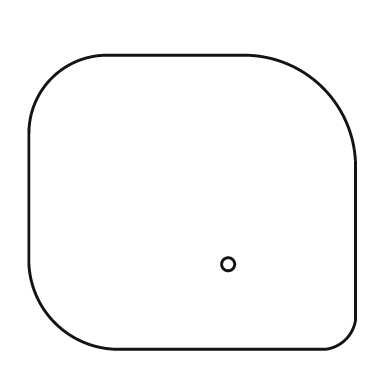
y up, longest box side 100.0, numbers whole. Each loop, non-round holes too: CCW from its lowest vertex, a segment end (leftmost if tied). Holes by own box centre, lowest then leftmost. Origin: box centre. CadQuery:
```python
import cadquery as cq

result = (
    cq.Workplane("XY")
    .moveTo(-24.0, -45.0)
    .lineTo(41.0, -45.0)
    .threePointArc((47.0, -42.0), (50.0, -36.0))
    .lineTo(50.0, 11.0)
    .threePointArc((40.0, 35.0), (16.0, 45.0))
    .lineTo(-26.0, 45.0)
    .threePointArc((-43.0, 38.0), (-50.0, 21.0))
    .lineTo(-50.0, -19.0)
    .threePointArc((-42.0, -37.0), (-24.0, -45.0))
    .close()
    .moveTo(11.0, -19.0)
    .circle(2.0)
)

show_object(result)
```